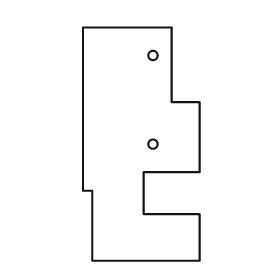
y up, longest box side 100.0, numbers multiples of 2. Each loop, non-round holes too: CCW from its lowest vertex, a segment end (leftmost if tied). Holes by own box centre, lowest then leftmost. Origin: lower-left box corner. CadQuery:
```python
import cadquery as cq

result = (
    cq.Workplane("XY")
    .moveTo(4.0, 0.0)
    .lineTo(50.0, 0.0)
    .lineTo(50.0, 20.0)
    .lineTo(26.0, 20.0)
    .lineTo(26.0, 38.0)
    .lineTo(50.0, 38.0)
    .lineTo(50.0, 68.0)
    .lineTo(38.0, 68.0)
    .lineTo(38.0, 100.0)
    .lineTo(0.0, 100.0)
    .lineTo(0.0, 30.0)
    .lineTo(4.0, 30.0)
    .close()
    .moveTo(30.0, 50.0)
    .circle(2.0)
    .moveTo(30.0, 88.0)
    .circle(2.0)
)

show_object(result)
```